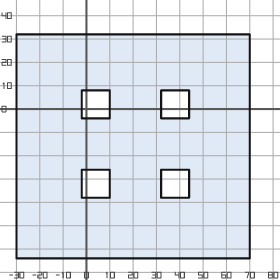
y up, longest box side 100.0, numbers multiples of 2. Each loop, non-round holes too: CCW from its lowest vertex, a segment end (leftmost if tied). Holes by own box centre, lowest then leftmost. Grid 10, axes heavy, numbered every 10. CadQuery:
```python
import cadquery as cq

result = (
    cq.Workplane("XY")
    .moveTo(-30.0, -64.0)
    .lineTo(70.0, -64.0)
    .lineTo(70.0, 32.0)
    .lineTo(-30.0, 32.0)
    .close()
    .moveTo(-2.0, -38.0)
    .lineTo(10.0, -38.0)
    .lineTo(10.0, -26.0)
    .lineTo(-2.0, -26.0)
    .close()
    .moveTo(32.0, -38.0)
    .lineTo(44.0, -38.0)
    .lineTo(44.0, -26.0)
    .lineTo(32.0, -26.0)
    .close()
    .moveTo(-2.0, -4.0)
    .lineTo(10.0, -4.0)
    .lineTo(10.0, 8.0)
    .lineTo(-2.0, 8.0)
    .close()
    .moveTo(32.0, -4.0)
    .lineTo(44.0, -4.0)
    .lineTo(44.0, 8.0)
    .lineTo(32.0, 8.0)
    .close()
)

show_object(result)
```